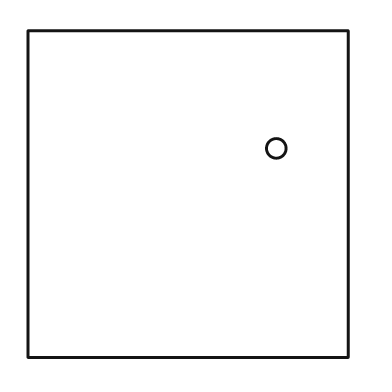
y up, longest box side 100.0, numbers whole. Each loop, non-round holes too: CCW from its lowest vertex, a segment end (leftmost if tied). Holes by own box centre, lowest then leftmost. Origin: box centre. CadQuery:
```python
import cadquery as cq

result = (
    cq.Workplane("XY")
    .moveTo(-49.0, -50.0)
    .lineTo(49.0, -50.0)
    .lineTo(49.0, 50.0)
    .lineTo(-49.0, 50.0)
    .close()
    .moveTo(27.0, 14.0)
    .circle(3.0)
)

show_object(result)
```